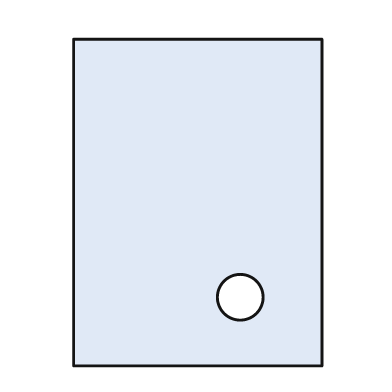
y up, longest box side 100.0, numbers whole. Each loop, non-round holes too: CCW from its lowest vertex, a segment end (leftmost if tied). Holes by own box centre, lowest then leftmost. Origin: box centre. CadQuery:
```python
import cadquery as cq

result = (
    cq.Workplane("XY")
    .moveTo(-38.0, -50.0)
    .lineTo(38.0, -50.0)
    .lineTo(38.0, 50.0)
    .lineTo(-38.0, 50.0)
    .close()
    .moveTo(13.0, -29.0)
    .circle(7.0)
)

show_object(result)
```